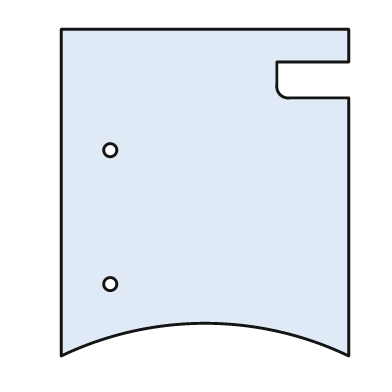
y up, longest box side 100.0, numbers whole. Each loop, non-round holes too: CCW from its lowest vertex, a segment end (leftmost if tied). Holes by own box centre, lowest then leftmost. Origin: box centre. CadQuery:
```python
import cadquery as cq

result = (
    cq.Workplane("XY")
    .moveTo(-44.0, -50.0)
    .threePointArc((0.0, -40.0), (44.0, -50.0))
    .lineTo(44.0, 29.0)
    .lineTo(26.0, 29.0)
    .threePointArc((23.0, 30.0), (22.0, 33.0))
    .lineTo(22.0, 40.0)
    .lineTo(44.0, 40.0)
    .lineTo(44.0, 50.0)
    .lineTo(-44.0, 50.0)
    .close()
    .moveTo(-29.0, -28.0)
    .circle(2.0)
    .moveTo(-29.0, 13.0)
    .circle(2.0)
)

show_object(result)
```